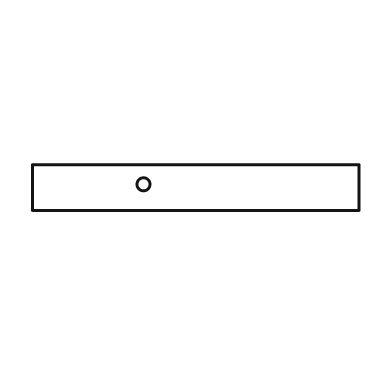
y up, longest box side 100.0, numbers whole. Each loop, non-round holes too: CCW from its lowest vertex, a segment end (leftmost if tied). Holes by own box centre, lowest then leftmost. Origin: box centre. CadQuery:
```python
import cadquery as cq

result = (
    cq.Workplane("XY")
    .moveTo(-50.0, -7.0)
    .lineTo(50.0, -7.0)
    .lineTo(50.0, 7.0)
    .lineTo(-50.0, 7.0)
    .close()
    .moveTo(-16.0, 1.0)
    .circle(2.0)
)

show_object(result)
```